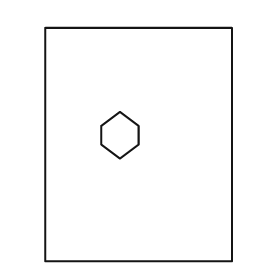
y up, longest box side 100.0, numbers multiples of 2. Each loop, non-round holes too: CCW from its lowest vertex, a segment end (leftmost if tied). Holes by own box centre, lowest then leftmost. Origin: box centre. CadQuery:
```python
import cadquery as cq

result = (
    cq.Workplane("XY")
    .moveTo(-40.0, -50.0)
    .lineTo(40.0, -50.0)
    .lineTo(40.0, 50.0)
    .lineTo(-40.0, 50.0)
    .close()
    .moveTo(-8.0, -6.0)
    .lineTo(0.0, 0.0)
    .lineTo(0.0, 8.0)
    .lineTo(-8.0, 14.0)
    .lineTo(-16.0, 8.0)
    .lineTo(-16.0, 0.0)
    .close()
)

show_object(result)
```